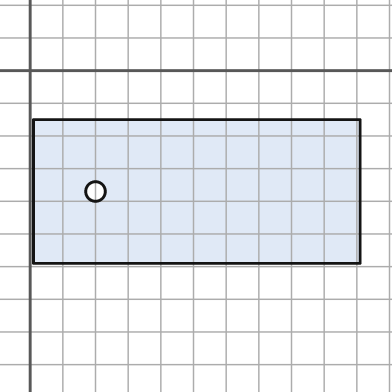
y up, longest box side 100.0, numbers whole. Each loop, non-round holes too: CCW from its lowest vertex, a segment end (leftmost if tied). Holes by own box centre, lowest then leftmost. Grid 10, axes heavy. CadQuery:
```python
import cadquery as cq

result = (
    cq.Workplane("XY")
    .moveTo(1.0, -59.0)
    .lineTo(101.0, -59.0)
    .lineTo(101.0, -15.0)
    .lineTo(1.0, -15.0)
    .close()
    .moveTo(20.0, -37.0)
    .circle(3.0)
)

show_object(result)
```